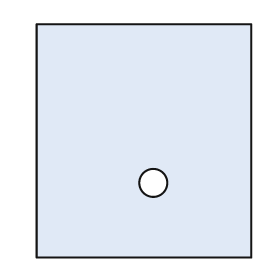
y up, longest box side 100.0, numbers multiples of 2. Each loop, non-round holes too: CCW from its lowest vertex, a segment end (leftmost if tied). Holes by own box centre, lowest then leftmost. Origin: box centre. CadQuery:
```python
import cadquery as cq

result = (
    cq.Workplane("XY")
    .moveTo(-46.0, -50.0)
    .lineTo(46.0, -50.0)
    .lineTo(46.0, 50.0)
    .lineTo(-46.0, 50.0)
    .close()
    .moveTo(4.0, -18.0)
    .circle(6.0)
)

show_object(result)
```